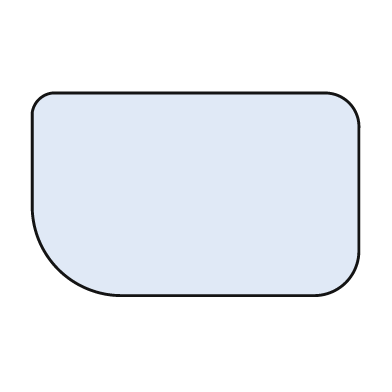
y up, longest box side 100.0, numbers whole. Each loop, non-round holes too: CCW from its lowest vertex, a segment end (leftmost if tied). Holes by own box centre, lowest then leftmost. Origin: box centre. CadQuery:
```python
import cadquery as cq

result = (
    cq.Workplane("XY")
    .moveTo(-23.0, -31.0)
    .lineTo(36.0, -31.0)
    .threePointArc((46.0, -27.0), (50.0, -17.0))
    .lineTo(50.0, 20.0)
    .threePointArc((47.0, 28.0), (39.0, 31.0))
    .lineTo(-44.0, 31.0)
    .threePointArc((-48.0, 29.0), (-50.0, 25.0))
    .lineTo(-50.0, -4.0)
    .threePointArc((-42.0, -23.0), (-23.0, -31.0))
    .close()
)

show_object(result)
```